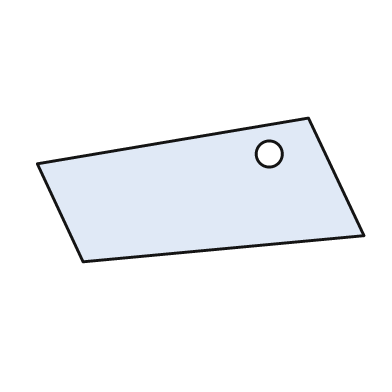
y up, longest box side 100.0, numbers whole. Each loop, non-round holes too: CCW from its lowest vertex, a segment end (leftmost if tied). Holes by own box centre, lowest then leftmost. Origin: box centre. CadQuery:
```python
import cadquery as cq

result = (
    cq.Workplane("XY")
    .moveTo(-36.0, -22.0)
    .lineTo(50.0, -14.0)
    .lineTo(33.0, 22.0)
    .lineTo(-50.0, 8.0)
    .close()
    .moveTo(21.0, 11.0)
    .circle(4.0)
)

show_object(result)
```